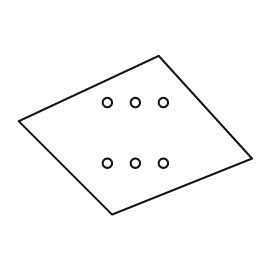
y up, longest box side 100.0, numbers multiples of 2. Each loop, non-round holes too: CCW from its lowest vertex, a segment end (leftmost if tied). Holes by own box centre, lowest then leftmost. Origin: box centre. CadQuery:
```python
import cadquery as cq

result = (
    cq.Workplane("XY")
    .moveTo(-10.0, -34.0)
    .lineTo(50.0, -10.0)
    .lineTo(10.0, 34.0)
    .lineTo(-50.0, 6.0)
    .close()
    .moveTo(-12.0, -12.0)
    .circle(2.0)
    .moveTo(0.0, -12.0)
    .circle(2.0)
    .moveTo(12.0, -12.0)
    .circle(2.0)
    .moveTo(-12.0, 14.0)
    .circle(2.0)
    .moveTo(0.0, 14.0)
    .circle(2.0)
    .moveTo(12.0, 14.0)
    .circle(2.0)
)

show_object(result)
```